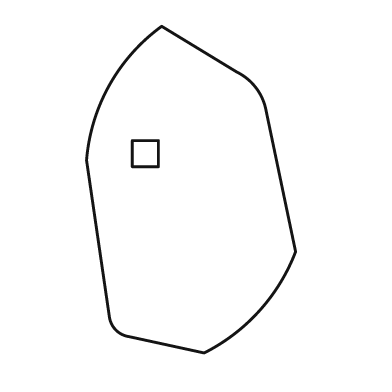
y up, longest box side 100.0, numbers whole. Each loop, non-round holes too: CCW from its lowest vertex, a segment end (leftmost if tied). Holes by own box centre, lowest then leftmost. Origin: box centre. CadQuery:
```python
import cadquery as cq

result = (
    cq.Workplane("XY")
    .moveTo(4.0, -50.0)
    .threePointArc((21.0, -37.0), (32.0, -19.0))
    .lineTo(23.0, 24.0)
    .threePointArc((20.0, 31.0), (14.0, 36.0))
    .lineTo(-9.0, 50.0)
    .threePointArc((-25.0, 32.0), (-32.0, 9.0))
    .lineTo(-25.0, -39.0)
    .threePointArc((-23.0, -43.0), (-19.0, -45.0))
    .close()
    .moveTo(-18.0, 7.0)
    .lineTo(-10.0, 7.0)
    .lineTo(-10.0, 15.0)
    .lineTo(-18.0, 15.0)
    .close()
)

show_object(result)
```